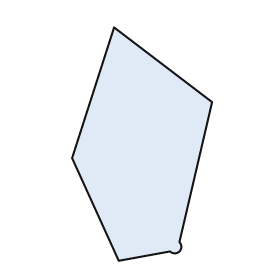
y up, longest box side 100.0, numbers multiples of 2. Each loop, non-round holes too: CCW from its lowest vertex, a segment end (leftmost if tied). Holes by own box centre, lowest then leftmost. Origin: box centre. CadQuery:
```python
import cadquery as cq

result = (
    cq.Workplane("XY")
    .moveTo(-10.0, -50.0)
    .lineTo(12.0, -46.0)
    .threePointArc((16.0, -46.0), (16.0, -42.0))
    .lineTo(30.0, 18.0)
    .lineTo(-12.0, 50.0)
    .lineTo(-30.0, -6.0)
    .close()
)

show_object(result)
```